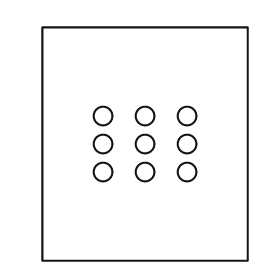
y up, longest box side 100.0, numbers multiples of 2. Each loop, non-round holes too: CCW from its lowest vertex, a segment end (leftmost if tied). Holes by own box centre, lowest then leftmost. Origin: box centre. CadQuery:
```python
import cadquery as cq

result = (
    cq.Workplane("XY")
    .moveTo(-44.0, -50.0)
    .lineTo(44.0, -50.0)
    .lineTo(44.0, 50.0)
    .lineTo(-44.0, 50.0)
    .close()
    .moveTo(-18.0, -12.0)
    .circle(4.0)
    .moveTo(0.0, -12.0)
    .circle(4.0)
    .moveTo(18.0, -12.0)
    .circle(4.0)
    .moveTo(-18.0, 0.0)
    .circle(4.0)
    .moveTo(0.0, 0.0)
    .circle(4.0)
    .moveTo(18.0, 0.0)
    .circle(4.0)
    .moveTo(-18.0, 12.0)
    .circle(4.0)
    .moveTo(0.0, 12.0)
    .circle(4.0)
    .moveTo(18.0, 12.0)
    .circle(4.0)
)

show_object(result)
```